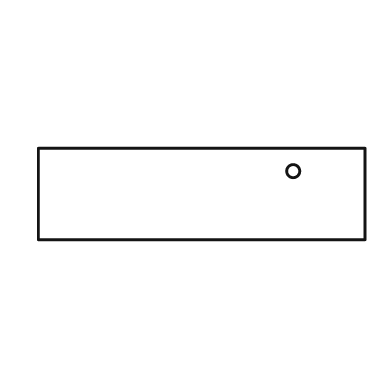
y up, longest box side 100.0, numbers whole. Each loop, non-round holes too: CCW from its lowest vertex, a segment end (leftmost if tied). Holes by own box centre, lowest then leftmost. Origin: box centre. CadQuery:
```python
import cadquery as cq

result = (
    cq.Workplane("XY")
    .moveTo(-50.0, -14.0)
    .lineTo(50.0, -14.0)
    .lineTo(50.0, 14.0)
    .lineTo(-50.0, 14.0)
    .close()
    .moveTo(28.0, 7.0)
    .circle(2.0)
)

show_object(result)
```